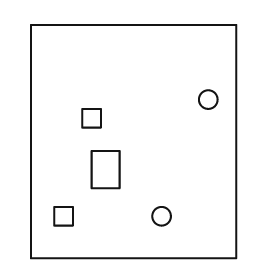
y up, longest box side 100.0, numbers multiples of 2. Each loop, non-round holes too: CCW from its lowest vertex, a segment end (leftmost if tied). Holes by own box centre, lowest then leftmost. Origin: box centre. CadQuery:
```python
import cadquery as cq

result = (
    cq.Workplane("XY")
    .moveTo(-44.0, -50.0)
    .lineTo(44.0, -50.0)
    .lineTo(44.0, 50.0)
    .lineTo(-44.0, 50.0)
    .close()
    .moveTo(-34.0, -36.0)
    .lineTo(-26.0, -36.0)
    .lineTo(-26.0, -28.0)
    .lineTo(-34.0, -28.0)
    .close()
    .moveTo(12.0, -32.0)
    .circle(4.0)
    .moveTo(-18.0, -20.0)
    .lineTo(-6.0, -20.0)
    .lineTo(-6.0, -4.0)
    .lineTo(-18.0, -4.0)
    .close()
    .moveTo(-22.0, 6.0)
    .lineTo(-14.0, 6.0)
    .lineTo(-14.0, 14.0)
    .lineTo(-22.0, 14.0)
    .close()
    .moveTo(32.0, 18.0)
    .circle(4.0)
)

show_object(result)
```